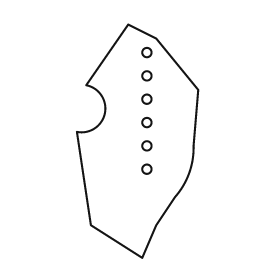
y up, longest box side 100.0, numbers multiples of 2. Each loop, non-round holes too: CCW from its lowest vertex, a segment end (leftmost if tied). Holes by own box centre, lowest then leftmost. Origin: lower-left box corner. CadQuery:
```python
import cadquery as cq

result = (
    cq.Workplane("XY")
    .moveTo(28.0, 0.0)
    .lineTo(34.0, 14.0)
    .lineTo(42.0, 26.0)
    .threePointArc((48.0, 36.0), (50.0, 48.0))
    .lineTo(52.0, 72.0)
    .lineTo(34.0, 94.0)
    .lineTo(22.0, 100.0)
    .lineTo(4.0, 74.0)
    .threePointArc((12.0, 62.0), (0.0, 54.0))
    .lineTo(6.0, 14.0)
    .close()
    .moveTo(30.0, 38.0)
    .circle(2.0)
    .moveTo(30.0, 48.0)
    .circle(2.0)
    .moveTo(30.0, 58.0)
    .circle(2.0)
    .moveTo(30.0, 68.0)
    .circle(2.0)
    .moveTo(30.0, 78.0)
    .circle(2.0)
    .moveTo(30.0, 88.0)
    .circle(2.0)
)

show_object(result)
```